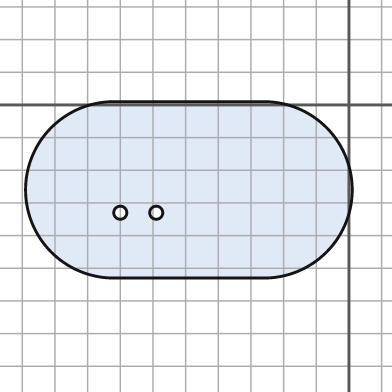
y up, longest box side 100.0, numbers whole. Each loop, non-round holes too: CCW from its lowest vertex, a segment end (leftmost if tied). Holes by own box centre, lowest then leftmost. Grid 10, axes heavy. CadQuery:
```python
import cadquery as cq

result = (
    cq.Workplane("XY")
    .moveTo(-72.0, -53.0)
    .lineTo(-26.0, -53.0)
    .threePointArc((1.0, -26.0), (-26.0, 1.0))
    .lineTo(-72.0, 1.0)
    .threePointArc((-99.0, -26.0), (-72.0, -53.0))
    .close()
    .moveTo(-70.0, -33.0)
    .circle(2.0)
    .moveTo(-59.0, -33.0)
    .circle(2.0)
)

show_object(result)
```